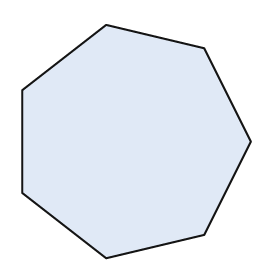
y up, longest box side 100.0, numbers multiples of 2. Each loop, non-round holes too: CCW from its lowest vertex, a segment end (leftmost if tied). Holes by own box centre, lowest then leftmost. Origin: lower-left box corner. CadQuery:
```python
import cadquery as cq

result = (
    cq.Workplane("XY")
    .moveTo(36.0, 0.0)
    .lineTo(78.0, 10.0)
    .lineTo(98.0, 50.0)
    .lineTo(78.0, 90.0)
    .lineTo(36.0, 100.0)
    .lineTo(0.0, 72.0)
    .lineTo(0.0, 28.0)
    .close()
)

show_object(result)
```